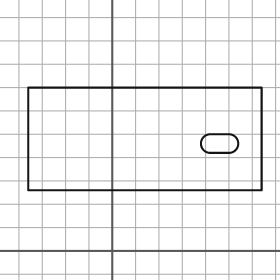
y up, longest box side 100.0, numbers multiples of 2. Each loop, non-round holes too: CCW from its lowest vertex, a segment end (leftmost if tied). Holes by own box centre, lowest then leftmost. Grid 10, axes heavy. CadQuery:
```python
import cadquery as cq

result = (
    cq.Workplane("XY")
    .moveTo(-36.0, 26.0)
    .lineTo(64.0, 26.0)
    .lineTo(64.0, 70.0)
    .lineTo(-36.0, 70.0)
    .close()
    .moveTo(42.0, 42.0)
    .lineTo(50.0, 42.0)
    .threePointArc((54.0, 46.0), (50.0, 50.0))
    .lineTo(42.0, 50.0)
    .threePointArc((38.0, 46.0), (42.0, 42.0))
    .close()
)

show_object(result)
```